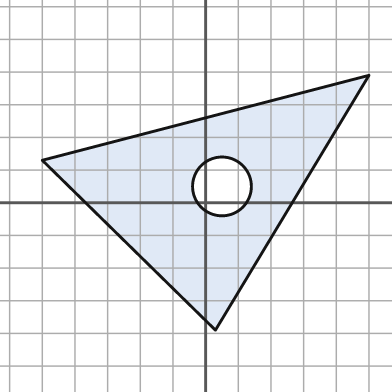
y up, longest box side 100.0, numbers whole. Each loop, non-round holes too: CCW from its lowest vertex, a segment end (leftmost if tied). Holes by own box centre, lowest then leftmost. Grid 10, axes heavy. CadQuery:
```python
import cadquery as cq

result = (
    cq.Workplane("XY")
    .moveTo(3.0, -39.0)
    .lineTo(50.0, 39.0)
    .lineTo(-50.0, 13.0)
    .close()
    .moveTo(5.0, 5.0)
    .circle(9.0)
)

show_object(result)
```